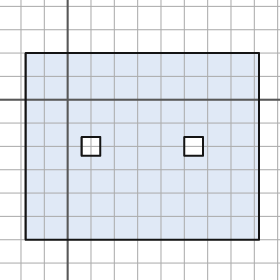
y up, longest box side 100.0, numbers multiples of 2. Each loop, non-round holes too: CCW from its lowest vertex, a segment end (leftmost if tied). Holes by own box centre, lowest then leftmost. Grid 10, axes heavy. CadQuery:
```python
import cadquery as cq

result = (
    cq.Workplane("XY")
    .moveTo(-18.0, -60.0)
    .lineTo(82.0, -60.0)
    .lineTo(82.0, 20.0)
    .lineTo(-18.0, 20.0)
    .close()
    .moveTo(6.0, -24.0)
    .lineTo(14.0, -24.0)
    .lineTo(14.0, -16.0)
    .lineTo(6.0, -16.0)
    .close()
    .moveTo(50.0, -24.0)
    .lineTo(58.0, -24.0)
    .lineTo(58.0, -16.0)
    .lineTo(50.0, -16.0)
    .close()
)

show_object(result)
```